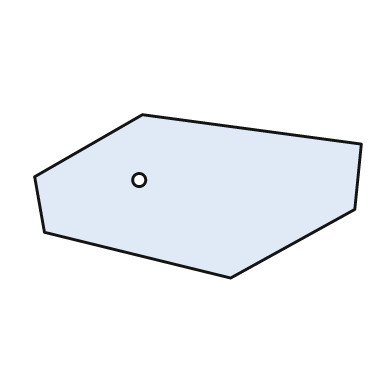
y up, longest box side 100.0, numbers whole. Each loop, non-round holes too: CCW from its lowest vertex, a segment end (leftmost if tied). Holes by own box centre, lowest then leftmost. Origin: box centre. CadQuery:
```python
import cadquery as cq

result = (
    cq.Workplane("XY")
    .moveTo(10.0, -25.0)
    .lineTo(48.0, -4.0)
    .lineTo(50.0, 16.0)
    .lineTo(-17.0, 25.0)
    .lineTo(-50.0, 6.0)
    .lineTo(-47.0, -11.0)
    .close()
    .moveTo(-18.0, 5.0)
    .circle(2.0)
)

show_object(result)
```